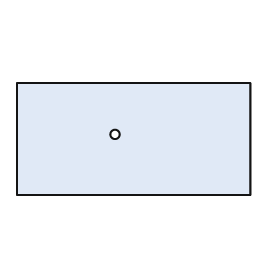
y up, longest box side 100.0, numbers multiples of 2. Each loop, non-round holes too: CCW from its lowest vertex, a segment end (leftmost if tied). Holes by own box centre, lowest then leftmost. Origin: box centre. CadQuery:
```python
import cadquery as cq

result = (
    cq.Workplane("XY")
    .moveTo(-50.0, -24.0)
    .lineTo(50.0, -24.0)
    .lineTo(50.0, 24.0)
    .lineTo(-50.0, 24.0)
    .close()
    .moveTo(-8.0, 2.0)
    .circle(2.0)
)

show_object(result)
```